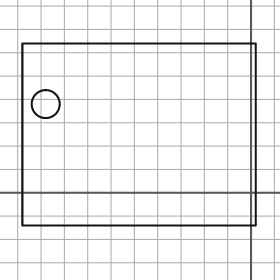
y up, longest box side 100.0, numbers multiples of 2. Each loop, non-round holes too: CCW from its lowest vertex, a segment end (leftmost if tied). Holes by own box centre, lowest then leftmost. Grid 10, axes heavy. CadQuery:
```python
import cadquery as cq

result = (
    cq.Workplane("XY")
    .moveTo(-98.0, -14.0)
    .lineTo(2.0, -14.0)
    .lineTo(2.0, 64.0)
    .lineTo(-98.0, 64.0)
    .close()
    .moveTo(-88.0, 38.0)
    .circle(6.0)
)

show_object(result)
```